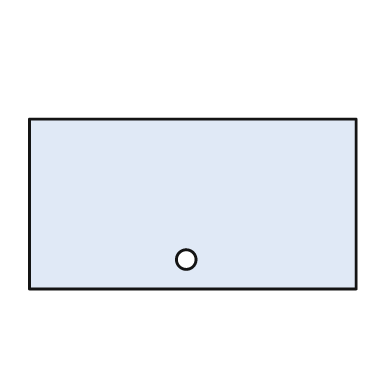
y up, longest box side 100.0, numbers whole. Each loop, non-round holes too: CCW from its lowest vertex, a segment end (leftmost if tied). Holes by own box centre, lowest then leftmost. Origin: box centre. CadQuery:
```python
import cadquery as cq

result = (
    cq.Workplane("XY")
    .moveTo(-50.0, -26.0)
    .lineTo(50.0, -26.0)
    .lineTo(50.0, 26.0)
    .lineTo(-50.0, 26.0)
    .close()
    .moveTo(-2.0, -17.0)
    .circle(3.0)
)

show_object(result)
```